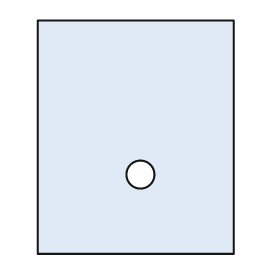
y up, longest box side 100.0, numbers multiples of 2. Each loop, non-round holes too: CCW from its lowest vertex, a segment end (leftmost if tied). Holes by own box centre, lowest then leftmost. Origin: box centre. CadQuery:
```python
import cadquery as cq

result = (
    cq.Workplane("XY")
    .moveTo(-42.0, -50.0)
    .lineTo(42.0, -50.0)
    .lineTo(42.0, 50.0)
    .lineTo(-42.0, 50.0)
    .close()
    .moveTo(2.0, -16.0)
    .circle(6.0)
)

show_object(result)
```